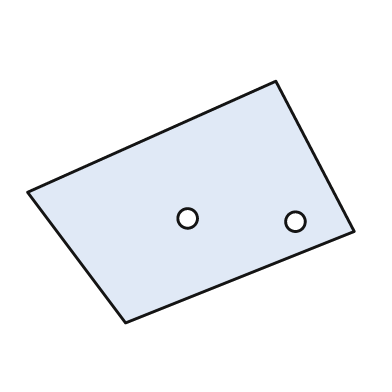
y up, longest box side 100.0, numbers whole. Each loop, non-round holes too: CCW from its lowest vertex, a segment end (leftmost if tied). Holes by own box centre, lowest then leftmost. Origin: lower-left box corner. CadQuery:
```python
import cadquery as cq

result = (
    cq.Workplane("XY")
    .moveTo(30.0, 0.0)
    .lineTo(100.0, 28.0)
    .lineTo(76.0, 74.0)
    .lineTo(0.0, 40.0)
    .close()
    .moveTo(82.0, 31.0)
    .circle(3.0)
    .moveTo(49.0, 32.0)
    .circle(3.0)
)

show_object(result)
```